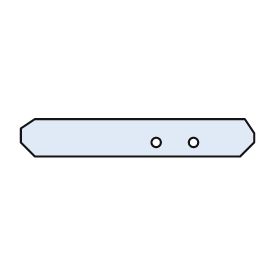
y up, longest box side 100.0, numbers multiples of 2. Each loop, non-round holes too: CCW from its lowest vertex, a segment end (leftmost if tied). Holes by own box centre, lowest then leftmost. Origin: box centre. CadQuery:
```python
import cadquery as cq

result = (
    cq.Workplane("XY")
    .moveTo(-44.0, -8.0)
    .lineTo(44.0, -8.0)
    .lineTo(50.0, -2.0)
    .lineTo(50.0, 2.0)
    .lineTo(46.0, 8.0)
    .lineTo(-44.0, 8.0)
    .lineTo(-50.0, 4.0)
    .lineTo(-50.0, -2.0)
    .close()
    .moveTo(8.0, -2.0)
    .circle(2.0)
    .moveTo(24.0, -2.0)
    .circle(2.0)
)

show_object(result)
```